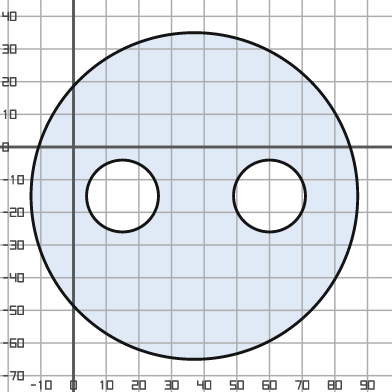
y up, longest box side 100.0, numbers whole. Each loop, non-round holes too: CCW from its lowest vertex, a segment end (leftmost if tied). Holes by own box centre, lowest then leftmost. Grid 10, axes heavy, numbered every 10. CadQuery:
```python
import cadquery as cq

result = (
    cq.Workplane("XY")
    .moveTo(37.0, -15.0)
    .circle(50.0)
    .moveTo(15.0, -15.0)
    .circle(11.0)
    .moveTo(60.0, -15.0)
    .circle(11.0)
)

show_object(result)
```